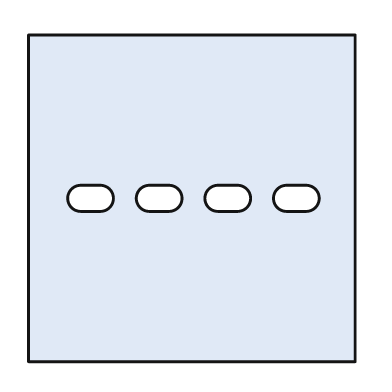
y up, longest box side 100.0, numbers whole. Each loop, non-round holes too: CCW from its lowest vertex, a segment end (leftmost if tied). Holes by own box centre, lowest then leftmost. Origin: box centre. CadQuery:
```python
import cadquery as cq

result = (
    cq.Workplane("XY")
    .moveTo(-50.0, -50.0)
    .lineTo(50.0, -50.0)
    .lineTo(50.0, 50.0)
    .lineTo(-50.0, 50.0)
    .close()
    .moveTo(-34.0, -4.0)
    .lineTo(-28.0, -4.0)
    .threePointArc((-24.0, 0.0), (-28.0, 4.0))
    .lineTo(-34.0, 4.0)
    .threePointArc((-38.0, 0.0), (-34.0, -4.0))
    .close()
    .moveTo(-13.0, -4.0)
    .lineTo(-7.0, -4.0)
    .threePointArc((-3.0, 0.0), (-7.0, 4.0))
    .lineTo(-13.0, 4.0)
    .threePointArc((-17.0, 0.0), (-13.0, -4.0))
    .close()
    .moveTo(8.0, -4.0)
    .lineTo(14.0, -4.0)
    .threePointArc((18.0, 0.0), (14.0, 4.0))
    .lineTo(8.0, 4.0)
    .threePointArc((4.0, 0.0), (8.0, -4.0))
    .close()
    .moveTo(29.0, -4.0)
    .lineTo(35.0, -4.0)
    .threePointArc((39.0, 0.0), (35.0, 4.0))
    .lineTo(29.0, 4.0)
    .threePointArc((25.0, 0.0), (29.0, -4.0))
    .close()
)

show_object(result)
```